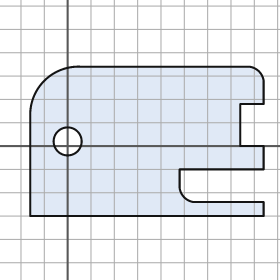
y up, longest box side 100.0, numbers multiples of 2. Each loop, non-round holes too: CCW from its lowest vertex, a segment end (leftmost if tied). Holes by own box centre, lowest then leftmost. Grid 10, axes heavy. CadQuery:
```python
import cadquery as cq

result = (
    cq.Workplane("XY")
    .moveTo(-16.0, -30.0)
    .lineTo(84.0, -30.0)
    .lineTo(84.0, -24.0)
    .lineTo(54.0, -24.0)
    .threePointArc((50.0, -22.0), (48.0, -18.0))
    .lineTo(48.0, -10.0)
    .lineTo(84.0, -10.0)
    .lineTo(84.0, 0.0)
    .lineTo(74.0, 0.0)
    .lineTo(74.0, 18.0)
    .lineTo(84.0, 18.0)
    .lineTo(84.0, 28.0)
    .threePointArc((82.0, 32.0), (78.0, 34.0))
    .lineTo(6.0, 34.0)
    .threePointArc((-10.0, 28.0), (-16.0, 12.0))
    .close()
    .moveTo(0.0, 2.0)
    .circle(6.0)
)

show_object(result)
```